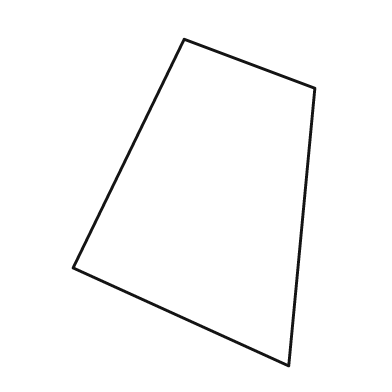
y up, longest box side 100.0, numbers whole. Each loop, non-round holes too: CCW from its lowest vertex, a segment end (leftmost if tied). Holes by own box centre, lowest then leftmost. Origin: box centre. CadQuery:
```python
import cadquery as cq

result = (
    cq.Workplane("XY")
    .moveTo(29.0, -50.0)
    .lineTo(37.0, 35.0)
    .lineTo(-3.0, 50.0)
    .lineTo(-37.0, -20.0)
    .close()
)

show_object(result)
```